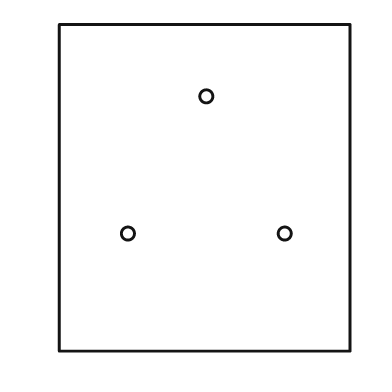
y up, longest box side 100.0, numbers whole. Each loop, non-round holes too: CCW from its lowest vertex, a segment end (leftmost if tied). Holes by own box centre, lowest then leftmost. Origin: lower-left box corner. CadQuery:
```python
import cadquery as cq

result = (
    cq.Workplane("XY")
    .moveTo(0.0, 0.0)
    .lineTo(89.0, 0.0)
    .lineTo(89.0, 100.0)
    .lineTo(0.0, 100.0)
    .close()
    .moveTo(21.0, 36.0)
    .circle(2.0)
    .moveTo(69.0, 36.0)
    .circle(2.0)
    .moveTo(45.0, 78.0)
    .circle(2.0)
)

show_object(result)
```